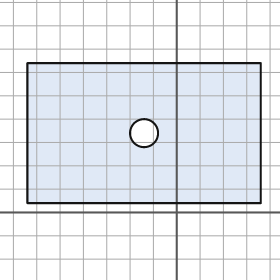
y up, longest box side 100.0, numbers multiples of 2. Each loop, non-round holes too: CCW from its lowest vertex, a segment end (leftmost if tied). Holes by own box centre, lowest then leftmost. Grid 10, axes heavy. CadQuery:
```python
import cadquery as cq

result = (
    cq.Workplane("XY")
    .moveTo(-64.0, 4.0)
    .lineTo(36.0, 4.0)
    .lineTo(36.0, 64.0)
    .lineTo(-64.0, 64.0)
    .close()
    .moveTo(-14.0, 34.0)
    .circle(6.0)
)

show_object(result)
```